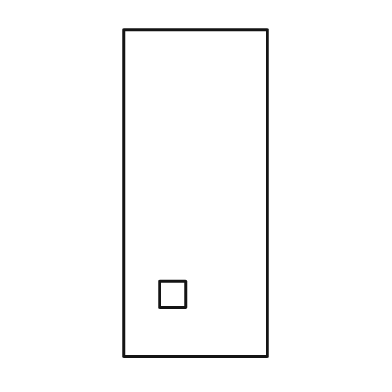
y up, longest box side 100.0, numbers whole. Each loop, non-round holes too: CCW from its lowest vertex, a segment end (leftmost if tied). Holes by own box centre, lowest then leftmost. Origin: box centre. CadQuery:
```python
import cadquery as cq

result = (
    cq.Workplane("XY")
    .moveTo(-22.0, -50.0)
    .lineTo(22.0, -50.0)
    .lineTo(22.0, 50.0)
    .lineTo(-22.0, 50.0)
    .close()
    .moveTo(-11.0, -35.0)
    .lineTo(-3.0, -35.0)
    .lineTo(-3.0, -27.0)
    .lineTo(-11.0, -27.0)
    .close()
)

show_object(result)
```